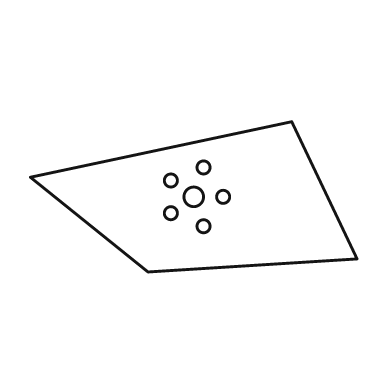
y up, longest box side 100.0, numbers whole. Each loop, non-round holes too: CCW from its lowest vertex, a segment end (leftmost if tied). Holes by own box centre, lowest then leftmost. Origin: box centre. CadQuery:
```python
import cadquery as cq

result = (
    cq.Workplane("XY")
    .moveTo(-14.0, -23.0)
    .lineTo(50.0, -19.0)
    .lineTo(30.0, 23.0)
    .lineTo(-50.0, 6.0)
    .close()
    .moveTo(3.0, -9.0)
    .circle(2.0)
    .moveTo(-7.0, -5.0)
    .circle(2.0)
    .moveTo(0.0, 0.0)
    .circle(3.0)
    .moveTo(9.0, 0.0)
    .circle(2.0)
    .moveTo(-7.0, 5.0)
    .circle(2.0)
    .moveTo(3.0, 9.0)
    .circle(2.0)
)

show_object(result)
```